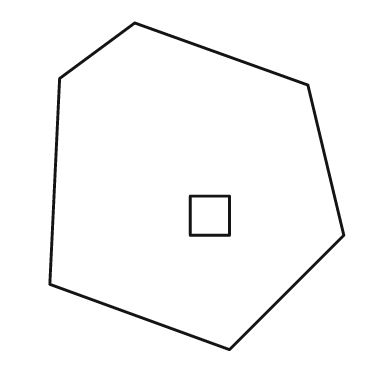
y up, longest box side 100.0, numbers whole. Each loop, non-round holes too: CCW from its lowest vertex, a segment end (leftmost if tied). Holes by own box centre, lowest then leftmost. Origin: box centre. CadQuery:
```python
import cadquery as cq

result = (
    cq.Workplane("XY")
    .moveTo(10.0, -50.0)
    .lineTo(45.0, -15.0)
    .lineTo(34.0, 31.0)
    .lineTo(-19.0, 50.0)
    .lineTo(-42.0, 33.0)
    .lineTo(-45.0, -30.0)
    .close()
    .moveTo(-2.0, -15.0)
    .lineTo(10.0, -15.0)
    .lineTo(10.0, -3.0)
    .lineTo(-2.0, -3.0)
    .close()
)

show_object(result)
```